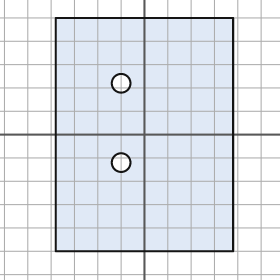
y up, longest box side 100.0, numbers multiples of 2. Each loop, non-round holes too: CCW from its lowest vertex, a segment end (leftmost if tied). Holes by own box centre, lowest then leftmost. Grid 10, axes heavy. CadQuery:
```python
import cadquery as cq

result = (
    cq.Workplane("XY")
    .moveTo(-38.0, -50.0)
    .lineTo(38.0, -50.0)
    .lineTo(38.0, 50.0)
    .lineTo(-38.0, 50.0)
    .close()
    .moveTo(-10.0, -12.0)
    .circle(4.0)
    .moveTo(-10.0, 22.0)
    .circle(4.0)
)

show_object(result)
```